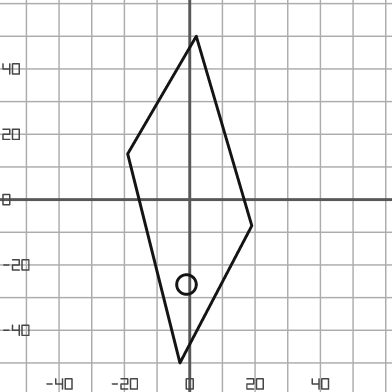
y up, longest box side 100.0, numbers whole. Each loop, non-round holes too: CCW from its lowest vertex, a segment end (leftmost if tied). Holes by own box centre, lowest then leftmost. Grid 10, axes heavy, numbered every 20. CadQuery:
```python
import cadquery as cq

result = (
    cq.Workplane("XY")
    .moveTo(-3.0, -50.0)
    .lineTo(19.0, -8.0)
    .lineTo(2.0, 50.0)
    .lineTo(-19.0, 14.0)
    .close()
    .moveTo(-1.0, -26.0)
    .circle(3.0)
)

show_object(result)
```